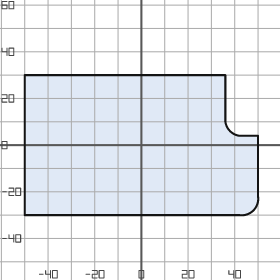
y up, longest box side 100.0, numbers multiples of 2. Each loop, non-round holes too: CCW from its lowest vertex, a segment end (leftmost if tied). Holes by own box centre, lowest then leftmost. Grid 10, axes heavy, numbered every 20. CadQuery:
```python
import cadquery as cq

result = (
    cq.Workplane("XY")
    .moveTo(-50.0, -30.0)
    .lineTo(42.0, -30.0)
    .threePointArc((48.0, -28.0), (50.0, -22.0))
    .lineTo(50.0, 4.0)
    .lineTo(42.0, 4.0)
    .threePointArc((38.0, 6.0), (36.0, 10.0))
    .lineTo(36.0, 30.0)
    .lineTo(-50.0, 30.0)
    .close()
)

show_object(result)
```